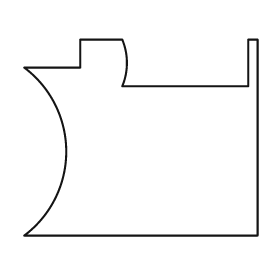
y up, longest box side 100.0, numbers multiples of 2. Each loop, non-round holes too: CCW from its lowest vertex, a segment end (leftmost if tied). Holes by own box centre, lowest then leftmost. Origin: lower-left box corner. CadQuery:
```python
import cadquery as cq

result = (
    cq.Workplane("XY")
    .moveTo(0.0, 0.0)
    .lineTo(100.0, 0.0)
    .lineTo(100.0, 84.0)
    .lineTo(96.0, 84.0)
    .lineTo(96.0, 64.0)
    .lineTo(42.0, 64.0)
    .threePointArc((44.0, 74.0), (42.0, 84.0))
    .lineTo(24.0, 84.0)
    .lineTo(24.0, 72.0)
    .lineTo(0.0, 72.0)
    .threePointArc((18.0, 36.0), (0.0, 0.0))
    .close()
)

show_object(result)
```